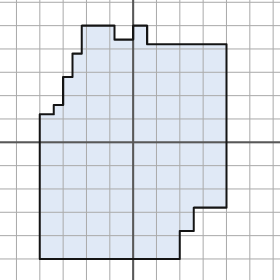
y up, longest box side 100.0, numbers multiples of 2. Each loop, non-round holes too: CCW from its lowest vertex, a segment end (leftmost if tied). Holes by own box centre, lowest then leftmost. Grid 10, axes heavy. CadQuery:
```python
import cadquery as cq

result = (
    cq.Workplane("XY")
    .moveTo(-40.0, -50.0)
    .lineTo(20.0, -50.0)
    .lineTo(20.0, -38.0)
    .lineTo(26.0, -38.0)
    .lineTo(26.0, -28.0)
    .lineTo(40.0, -28.0)
    .lineTo(40.0, 42.0)
    .lineTo(6.0, 42.0)
    .lineTo(6.0, 50.0)
    .lineTo(0.0, 50.0)
    .lineTo(0.0, 44.0)
    .lineTo(-8.0, 44.0)
    .lineTo(-8.0, 50.0)
    .lineTo(-22.0, 50.0)
    .lineTo(-22.0, 38.0)
    .lineTo(-26.0, 38.0)
    .lineTo(-26.0, 28.0)
    .lineTo(-30.0, 28.0)
    .lineTo(-30.0, 16.0)
    .lineTo(-34.0, 16.0)
    .lineTo(-34.0, 12.0)
    .lineTo(-40.0, 12.0)
    .close()
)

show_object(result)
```